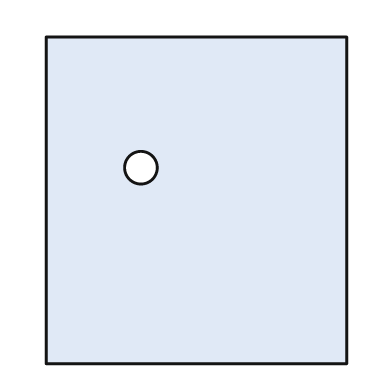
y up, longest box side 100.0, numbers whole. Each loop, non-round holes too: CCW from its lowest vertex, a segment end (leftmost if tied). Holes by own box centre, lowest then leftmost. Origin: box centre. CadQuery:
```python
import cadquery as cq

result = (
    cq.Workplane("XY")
    .moveTo(-46.0, -50.0)
    .lineTo(46.0, -50.0)
    .lineTo(46.0, 50.0)
    .lineTo(-46.0, 50.0)
    .close()
    .moveTo(-17.0, 10.0)
    .circle(5.0)
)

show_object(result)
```